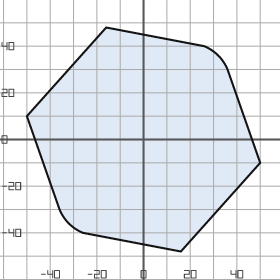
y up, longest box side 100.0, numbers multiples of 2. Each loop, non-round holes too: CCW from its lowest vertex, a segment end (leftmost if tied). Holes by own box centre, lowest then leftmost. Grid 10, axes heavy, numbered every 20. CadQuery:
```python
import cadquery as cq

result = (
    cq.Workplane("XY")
    .moveTo(16.0, -48.0)
    .lineTo(50.0, -10.0)
    .lineTo(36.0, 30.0)
    .threePointArc((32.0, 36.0), (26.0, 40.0))
    .lineTo(-16.0, 48.0)
    .lineTo(-50.0, 10.0)
    .lineTo(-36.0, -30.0)
    .threePointArc((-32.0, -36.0), (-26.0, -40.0))
    .close()
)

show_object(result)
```